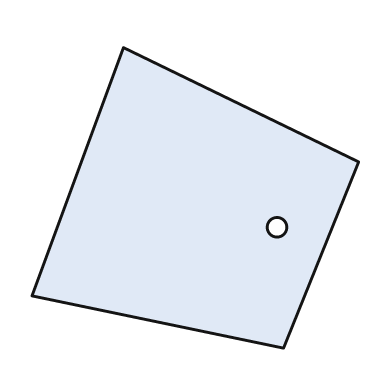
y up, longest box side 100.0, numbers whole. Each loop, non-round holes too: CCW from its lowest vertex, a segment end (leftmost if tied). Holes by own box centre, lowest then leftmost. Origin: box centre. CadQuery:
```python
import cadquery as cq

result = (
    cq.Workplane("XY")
    .moveTo(27.0, -46.0)
    .lineTo(50.0, 11.0)
    .lineTo(-22.0, 46.0)
    .lineTo(-50.0, -30.0)
    .close()
    .moveTo(25.0, -9.0)
    .circle(3.0)
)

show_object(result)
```